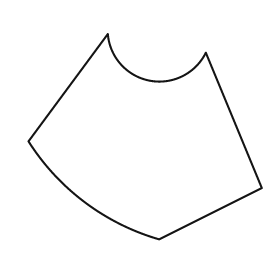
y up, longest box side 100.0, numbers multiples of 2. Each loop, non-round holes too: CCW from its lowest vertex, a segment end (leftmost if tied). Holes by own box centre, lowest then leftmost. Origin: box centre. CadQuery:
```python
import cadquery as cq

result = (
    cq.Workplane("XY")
    .moveTo(6.0, -44.0)
    .lineTo(50.0, -22.0)
    .lineTo(26.0, 36.0)
    .threePointArc((2.0, 24.0), (-16.0, 44.0))
    .lineTo(-50.0, -2.0)
    .threePointArc((-26.0, -28.0), (6.0, -44.0))
    .close()
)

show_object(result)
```